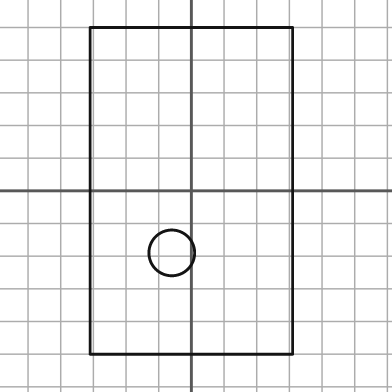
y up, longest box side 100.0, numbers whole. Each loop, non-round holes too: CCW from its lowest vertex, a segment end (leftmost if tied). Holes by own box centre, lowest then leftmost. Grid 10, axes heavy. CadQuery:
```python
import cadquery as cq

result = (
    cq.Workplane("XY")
    .moveTo(-31.0, -50.0)
    .lineTo(31.0, -50.0)
    .lineTo(31.0, 50.0)
    .lineTo(-31.0, 50.0)
    .close()
    .moveTo(-6.0, -19.0)
    .circle(7.0)
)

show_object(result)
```